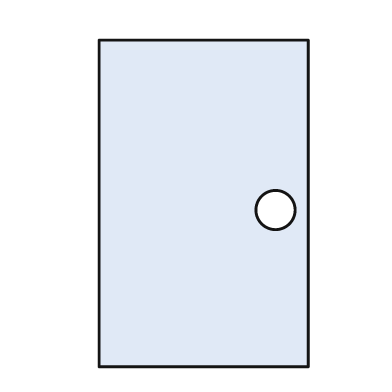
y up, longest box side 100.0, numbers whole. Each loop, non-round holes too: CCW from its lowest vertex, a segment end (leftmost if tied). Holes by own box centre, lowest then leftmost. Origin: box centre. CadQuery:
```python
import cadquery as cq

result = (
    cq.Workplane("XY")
    .moveTo(-32.0, -50.0)
    .lineTo(32.0, -50.0)
    .lineTo(32.0, 50.0)
    .lineTo(-32.0, 50.0)
    .close()
    .moveTo(22.0, -2.0)
    .circle(6.0)
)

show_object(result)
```